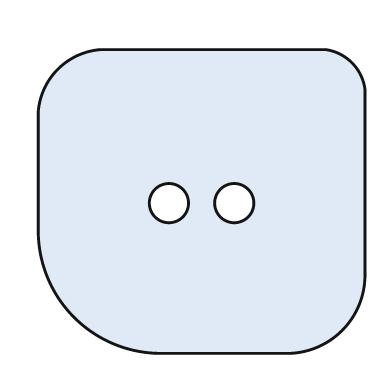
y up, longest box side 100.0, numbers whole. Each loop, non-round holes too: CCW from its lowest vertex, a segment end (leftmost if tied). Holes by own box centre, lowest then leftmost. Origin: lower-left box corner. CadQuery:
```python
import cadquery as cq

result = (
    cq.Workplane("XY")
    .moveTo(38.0, 0.0)
    .lineTo(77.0, 0.0)
    .threePointArc((93.0, 7.0), (100.0, 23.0))
    .lineTo(100.0, 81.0)
    .threePointArc((96.0, 89.0), (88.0, 93.0))
    .lineTo(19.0, 93.0)
    .threePointArc((6.0, 87.0), (0.0, 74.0))
    .lineTo(0.0, 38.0)
    .threePointArc((11.0, 11.0), (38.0, 0.0))
    .close()
    .moveTo(40.0, 46.0)
    .circle(6.0)
    .moveTo(60.0, 46.0)
    .circle(6.0)
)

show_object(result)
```